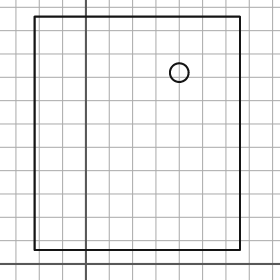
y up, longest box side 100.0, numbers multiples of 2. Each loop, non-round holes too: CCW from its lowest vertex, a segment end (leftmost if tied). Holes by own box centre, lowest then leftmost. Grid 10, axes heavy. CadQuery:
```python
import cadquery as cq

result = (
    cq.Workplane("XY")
    .moveTo(-22.0, 6.0)
    .lineTo(66.0, 6.0)
    .lineTo(66.0, 106.0)
    .lineTo(-22.0, 106.0)
    .close()
    .moveTo(40.0, 82.0)
    .circle(4.0)
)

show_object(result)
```